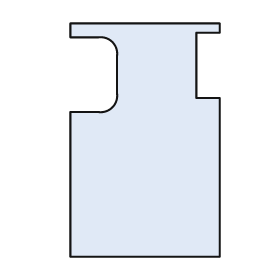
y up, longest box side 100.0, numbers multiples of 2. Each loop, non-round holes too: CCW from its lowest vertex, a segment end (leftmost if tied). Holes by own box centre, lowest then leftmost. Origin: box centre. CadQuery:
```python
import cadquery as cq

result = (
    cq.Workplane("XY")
    .moveTo(-32.0, -50.0)
    .lineTo(32.0, -50.0)
    .lineTo(32.0, 18.0)
    .lineTo(22.0, 18.0)
    .lineTo(22.0, 46.0)
    .lineTo(32.0, 46.0)
    .lineTo(32.0, 50.0)
    .lineTo(-32.0, 50.0)
    .lineTo(-32.0, 44.0)
    .lineTo(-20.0, 44.0)
    .threePointArc((-14.0, 42.0), (-12.0, 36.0))
    .lineTo(-12.0, 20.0)
    .threePointArc((-14.0, 14.0), (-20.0, 12.0))
    .lineTo(-32.0, 12.0)
    .close()
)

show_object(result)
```